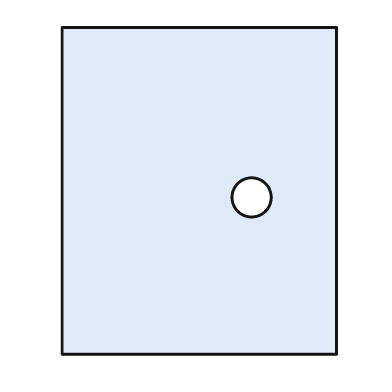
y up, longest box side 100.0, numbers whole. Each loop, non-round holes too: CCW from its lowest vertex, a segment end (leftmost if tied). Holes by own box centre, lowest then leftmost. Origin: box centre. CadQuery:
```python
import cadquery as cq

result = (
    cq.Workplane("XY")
    .moveTo(-42.0, -50.0)
    .lineTo(42.0, -50.0)
    .lineTo(42.0, 50.0)
    .lineTo(-42.0, 50.0)
    .close()
    .moveTo(16.0, -2.0)
    .circle(6.0)
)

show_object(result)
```